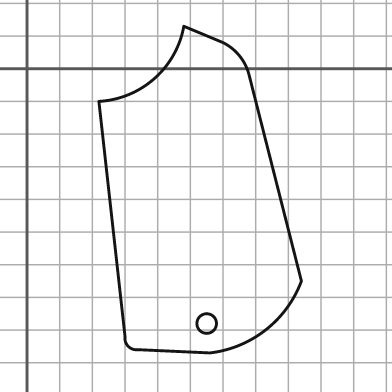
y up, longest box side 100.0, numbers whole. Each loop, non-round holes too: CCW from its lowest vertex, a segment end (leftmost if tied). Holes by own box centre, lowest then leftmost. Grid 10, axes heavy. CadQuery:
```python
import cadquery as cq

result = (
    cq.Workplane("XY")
    .moveTo(56.0, -87.0)
    .threePointArc((73.0, -80.0), (84.0, -65.0))
    .lineTo(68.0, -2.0)
    .threePointArc((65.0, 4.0), (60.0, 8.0))
    .lineTo(48.0, 13.0)
    .threePointArc((39.0, -3.0), (22.0, -10.0))
    .lineTo(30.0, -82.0)
    .threePointArc((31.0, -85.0), (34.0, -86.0))
    .close()
    .moveTo(55.0, -78.0)
    .circle(3.0)
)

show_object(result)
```